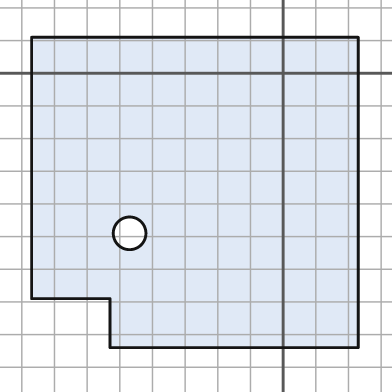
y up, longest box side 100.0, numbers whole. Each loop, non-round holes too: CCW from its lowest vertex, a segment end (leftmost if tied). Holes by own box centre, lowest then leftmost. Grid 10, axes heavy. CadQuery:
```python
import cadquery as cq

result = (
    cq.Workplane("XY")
    .moveTo(-53.0, -84.0)
    .lineTo(23.0, -84.0)
    .lineTo(23.0, 11.0)
    .lineTo(-77.0, 11.0)
    .lineTo(-77.0, -69.0)
    .lineTo(-53.0, -69.0)
    .close()
    .moveTo(-47.0, -49.0)
    .circle(5.0)
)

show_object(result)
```